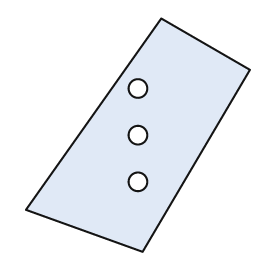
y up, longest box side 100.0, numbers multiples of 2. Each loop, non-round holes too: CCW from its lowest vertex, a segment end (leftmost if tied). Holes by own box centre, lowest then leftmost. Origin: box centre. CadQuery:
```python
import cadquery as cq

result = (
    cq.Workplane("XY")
    .moveTo(2.0, -50.0)
    .lineTo(48.0, 28.0)
    .lineTo(10.0, 50.0)
    .lineTo(-48.0, -32.0)
    .close()
    .moveTo(0.0, -20.0)
    .circle(4.0)
    .moveTo(0.0, 0.0)
    .circle(4.0)
    .moveTo(0.0, 20.0)
    .circle(4.0)
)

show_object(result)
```